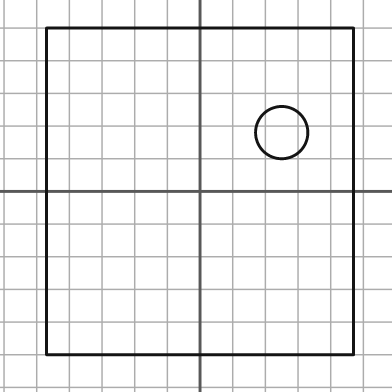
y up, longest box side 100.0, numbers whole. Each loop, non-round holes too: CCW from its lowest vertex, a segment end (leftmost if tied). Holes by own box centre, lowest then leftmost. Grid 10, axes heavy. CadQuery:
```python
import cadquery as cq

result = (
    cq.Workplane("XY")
    .moveTo(-47.0, -50.0)
    .lineTo(47.0, -50.0)
    .lineTo(47.0, 50.0)
    .lineTo(-47.0, 50.0)
    .close()
    .moveTo(25.0, 18.0)
    .circle(8.0)
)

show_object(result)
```